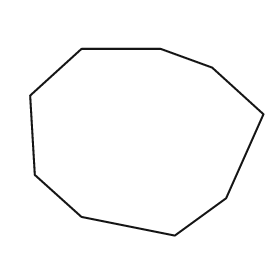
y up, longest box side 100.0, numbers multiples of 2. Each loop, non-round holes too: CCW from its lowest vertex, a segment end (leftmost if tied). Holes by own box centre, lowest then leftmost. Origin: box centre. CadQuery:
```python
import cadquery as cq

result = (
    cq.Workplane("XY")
    .moveTo(12.0, -40.0)
    .lineTo(34.0, -24.0)
    .lineTo(50.0, 12.0)
    .lineTo(28.0, 32.0)
    .lineTo(6.0, 40.0)
    .lineTo(-28.0, 40.0)
    .lineTo(-50.0, 20.0)
    .lineTo(-48.0, -14.0)
    .lineTo(-28.0, -32.0)
    .close()
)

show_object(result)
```